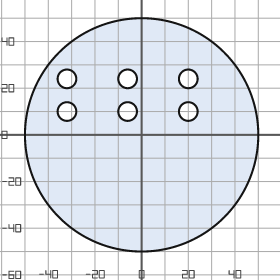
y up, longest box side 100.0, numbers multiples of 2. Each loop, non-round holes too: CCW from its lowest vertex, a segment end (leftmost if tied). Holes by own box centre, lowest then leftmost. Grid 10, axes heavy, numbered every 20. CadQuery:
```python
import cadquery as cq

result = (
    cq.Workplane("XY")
    .moveTo(0.0, 0.0)
    .circle(50.0)
    .moveTo(-32.0, 10.0)
    .circle(4.0)
    .moveTo(-6.0, 10.0)
    .circle(4.0)
    .moveTo(20.0, 10.0)
    .circle(4.0)
    .moveTo(-32.0, 24.0)
    .circle(4.0)
    .moveTo(-6.0, 24.0)
    .circle(4.0)
    .moveTo(20.0, 24.0)
    .circle(4.0)
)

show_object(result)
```